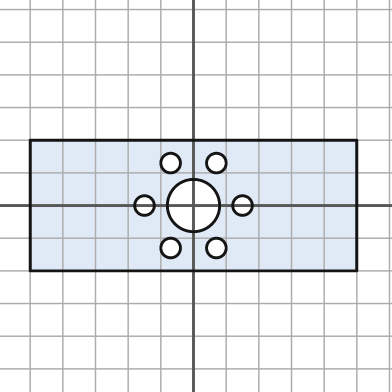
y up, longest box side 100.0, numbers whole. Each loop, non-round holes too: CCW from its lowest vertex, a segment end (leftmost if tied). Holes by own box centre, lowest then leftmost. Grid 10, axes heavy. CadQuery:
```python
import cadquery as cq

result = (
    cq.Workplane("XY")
    .moveTo(-50.0, -20.0)
    .lineTo(50.0, -20.0)
    .lineTo(50.0, 20.0)
    .lineTo(-50.0, 20.0)
    .close()
    .moveTo(-7.0, -13.0)
    .circle(3.0)
    .moveTo(7.0, -13.0)
    .circle(3.0)
    .moveTo(-15.0, 0.0)
    .circle(3.0)
    .moveTo(0.0, 0.0)
    .circle(8.0)
    .moveTo(15.0, 0.0)
    .circle(3.0)
    .moveTo(-7.0, 13.0)
    .circle(3.0)
    .moveTo(7.0, 13.0)
    .circle(3.0)
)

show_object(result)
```